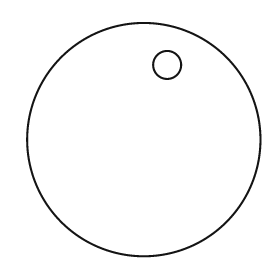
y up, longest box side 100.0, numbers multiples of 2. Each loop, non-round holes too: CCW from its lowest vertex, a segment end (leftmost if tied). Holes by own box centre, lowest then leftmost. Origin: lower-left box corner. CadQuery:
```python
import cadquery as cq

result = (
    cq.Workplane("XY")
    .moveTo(50.0, 50.0)
    .circle(50.0)
    .moveTo(60.0, 82.0)
    .circle(6.0)
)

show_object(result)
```